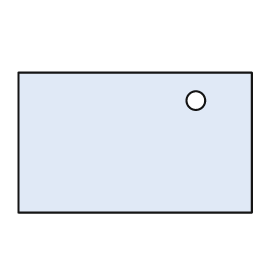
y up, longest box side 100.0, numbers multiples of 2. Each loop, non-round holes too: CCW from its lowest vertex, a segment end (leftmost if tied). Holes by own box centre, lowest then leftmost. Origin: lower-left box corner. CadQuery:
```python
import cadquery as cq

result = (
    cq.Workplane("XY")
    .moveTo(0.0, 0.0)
    .lineTo(100.0, 0.0)
    .lineTo(100.0, 60.0)
    .lineTo(0.0, 60.0)
    .close()
    .moveTo(76.0, 48.0)
    .circle(4.0)
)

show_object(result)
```